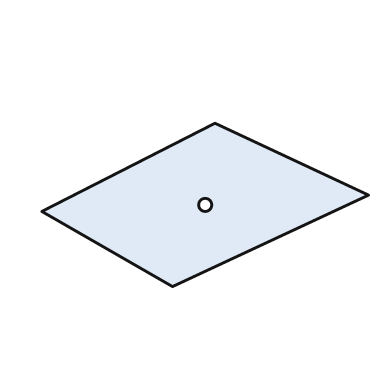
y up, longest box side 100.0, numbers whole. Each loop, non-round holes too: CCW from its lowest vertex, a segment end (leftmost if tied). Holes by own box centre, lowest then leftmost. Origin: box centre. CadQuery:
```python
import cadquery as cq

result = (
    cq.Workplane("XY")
    .moveTo(-10.0, -25.0)
    .lineTo(50.0, 3.0)
    .lineTo(3.0, 25.0)
    .lineTo(-50.0, -2.0)
    .close()
    .moveTo(0.0, 0.0)
    .circle(2.0)
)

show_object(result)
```